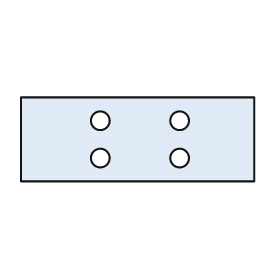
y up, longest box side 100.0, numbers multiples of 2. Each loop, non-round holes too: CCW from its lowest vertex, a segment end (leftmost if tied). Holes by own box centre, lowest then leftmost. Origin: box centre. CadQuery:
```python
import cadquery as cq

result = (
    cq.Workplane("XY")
    .moveTo(-50.0, -18.0)
    .lineTo(50.0, -18.0)
    .lineTo(50.0, 18.0)
    .lineTo(-50.0, 18.0)
    .close()
    .moveTo(-16.0, -8.0)
    .circle(4.0)
    .moveTo(18.0, -8.0)
    .circle(4.0)
    .moveTo(-16.0, 8.0)
    .circle(4.0)
    .moveTo(18.0, 8.0)
    .circle(4.0)
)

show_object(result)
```